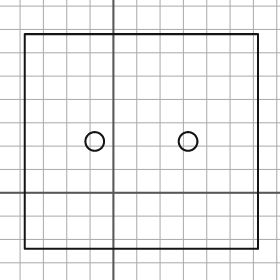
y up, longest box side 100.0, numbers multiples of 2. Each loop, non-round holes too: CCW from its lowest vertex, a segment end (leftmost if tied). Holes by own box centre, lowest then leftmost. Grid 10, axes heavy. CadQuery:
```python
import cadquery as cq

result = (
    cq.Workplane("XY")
    .moveTo(-38.0, -24.0)
    .lineTo(62.0, -24.0)
    .lineTo(62.0, 68.0)
    .lineTo(-38.0, 68.0)
    .close()
    .moveTo(-8.0, 22.0)
    .circle(4.0)
    .moveTo(32.0, 22.0)
    .circle(4.0)
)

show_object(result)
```